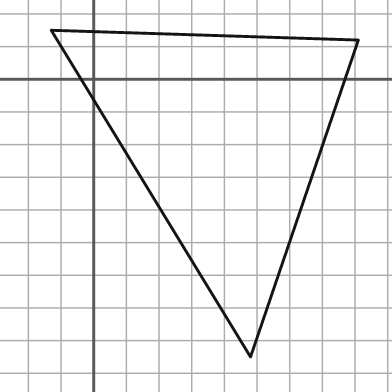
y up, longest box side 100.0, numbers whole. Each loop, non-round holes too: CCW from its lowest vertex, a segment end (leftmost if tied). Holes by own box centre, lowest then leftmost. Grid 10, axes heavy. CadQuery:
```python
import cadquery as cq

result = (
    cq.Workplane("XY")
    .moveTo(48.0, -85.0)
    .lineTo(81.0, 12.0)
    .lineTo(-13.0, 15.0)
    .close()
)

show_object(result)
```